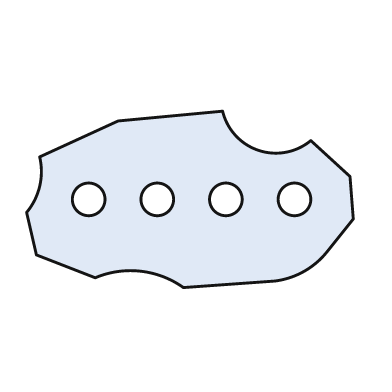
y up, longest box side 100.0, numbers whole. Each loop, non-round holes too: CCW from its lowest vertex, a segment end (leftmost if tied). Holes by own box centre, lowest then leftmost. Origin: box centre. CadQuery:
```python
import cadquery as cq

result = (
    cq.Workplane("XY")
    .moveTo(-2.0, -27.0)
    .lineTo(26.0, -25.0)
    .threePointArc((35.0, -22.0), (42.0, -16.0))
    .lineTo(50.0, -6.0)
    .lineTo(49.0, 7.0)
    .lineTo(37.0, 18.0)
    .threePointArc((21.0, 15.0), (10.0, 27.0))
    .lineTo(-22.0, 24.0)
    .lineTo(-46.0, 13.0)
    .threePointArc((-46.0, 4.0), (-50.0, -4.0))
    .lineTo(-47.0, -17.0)
    .lineTo(-29.0, -24.0)
    .threePointArc((-15.0, -22.0), (-2.0, -27.0))
    .close()
    .moveTo(-31.0, 0.0)
    .circle(5.0)
    .moveTo(-10.0, 0.0)
    .circle(5.0)
    .moveTo(11.0, 0.0)
    .circle(5.0)
    .moveTo(32.0, 0.0)
    .circle(5.0)
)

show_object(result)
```